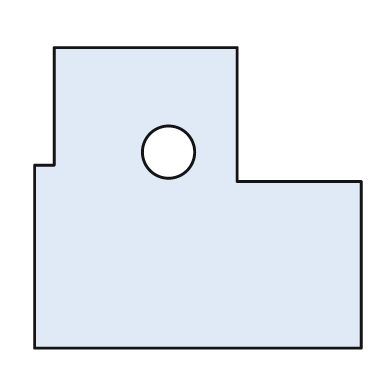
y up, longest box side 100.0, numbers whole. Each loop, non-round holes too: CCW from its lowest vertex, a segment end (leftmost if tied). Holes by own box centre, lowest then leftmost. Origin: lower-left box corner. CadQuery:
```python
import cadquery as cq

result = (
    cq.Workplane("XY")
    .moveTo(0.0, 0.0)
    .lineTo(100.0, 0.0)
    .lineTo(100.0, 51.0)
    .lineTo(62.0, 51.0)
    .lineTo(62.0, 92.0)
    .lineTo(6.0, 92.0)
    .lineTo(6.0, 56.0)
    .lineTo(0.0, 56.0)
    .close()
    .moveTo(41.0, 60.0)
    .circle(8.0)
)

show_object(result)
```